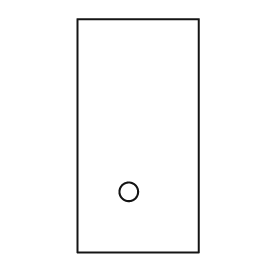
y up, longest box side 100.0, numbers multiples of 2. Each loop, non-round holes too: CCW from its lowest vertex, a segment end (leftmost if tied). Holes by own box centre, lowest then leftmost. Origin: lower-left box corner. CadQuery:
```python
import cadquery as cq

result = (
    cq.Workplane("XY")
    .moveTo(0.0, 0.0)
    .lineTo(52.0, 0.0)
    .lineTo(52.0, 100.0)
    .lineTo(0.0, 100.0)
    .close()
    .moveTo(22.0, 26.0)
    .circle(4.0)
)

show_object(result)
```